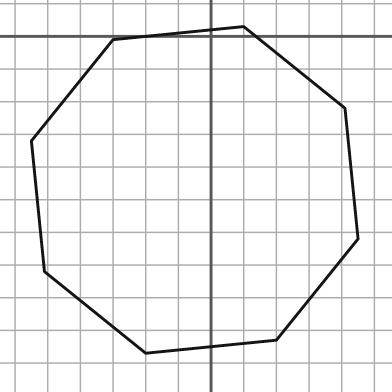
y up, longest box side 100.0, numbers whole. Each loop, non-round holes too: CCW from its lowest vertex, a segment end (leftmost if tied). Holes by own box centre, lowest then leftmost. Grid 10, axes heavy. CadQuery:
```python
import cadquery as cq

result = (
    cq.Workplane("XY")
    .moveTo(-20.0, -97.0)
    .lineTo(20.0, -93.0)
    .lineTo(45.0, -62.0)
    .lineTo(41.0, -22.0)
    .lineTo(10.0, 3.0)
    .lineTo(-30.0, -1.0)
    .lineTo(-55.0, -32.0)
    .lineTo(-51.0, -72.0)
    .close()
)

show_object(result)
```